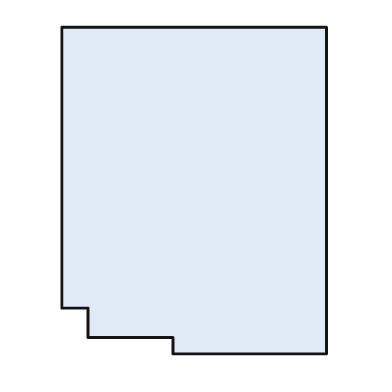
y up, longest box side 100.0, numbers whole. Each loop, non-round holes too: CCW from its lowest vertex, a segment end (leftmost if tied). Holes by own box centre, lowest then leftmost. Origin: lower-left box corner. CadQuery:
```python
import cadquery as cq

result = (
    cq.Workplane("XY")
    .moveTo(34.0, 0.0)
    .lineTo(81.0, 0.0)
    .lineTo(81.0, 100.0)
    .lineTo(0.0, 100.0)
    .lineTo(0.0, 14.0)
    .lineTo(8.0, 14.0)
    .lineTo(8.0, 5.0)
    .lineTo(34.0, 5.0)
    .close()
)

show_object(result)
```